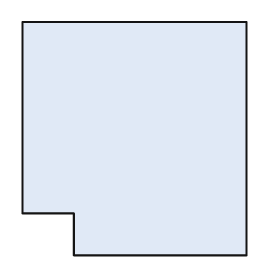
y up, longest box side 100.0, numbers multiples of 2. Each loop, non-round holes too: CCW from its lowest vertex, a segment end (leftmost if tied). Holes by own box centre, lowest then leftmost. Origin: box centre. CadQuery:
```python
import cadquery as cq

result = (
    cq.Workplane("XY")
    .moveTo(-26.0, -50.0)
    .lineTo(48.0, -50.0)
    .lineTo(48.0, 50.0)
    .lineTo(-48.0, 50.0)
    .lineTo(-48.0, -32.0)
    .lineTo(-26.0, -32.0)
    .close()
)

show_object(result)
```